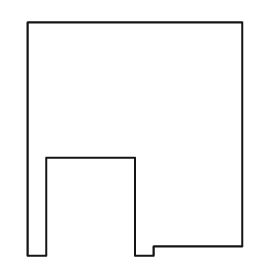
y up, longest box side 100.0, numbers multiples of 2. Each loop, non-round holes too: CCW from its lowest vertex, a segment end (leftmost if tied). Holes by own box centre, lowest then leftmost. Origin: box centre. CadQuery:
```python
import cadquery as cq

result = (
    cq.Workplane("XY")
    .moveTo(-46.0, -50.0)
    .lineTo(-38.0, -50.0)
    .lineTo(-38.0, -8.0)
    .lineTo(0.0, -8.0)
    .lineTo(0.0, -50.0)
    .lineTo(8.0, -50.0)
    .lineTo(8.0, -46.0)
    .lineTo(46.0, -46.0)
    .lineTo(46.0, 50.0)
    .lineTo(-46.0, 50.0)
    .close()
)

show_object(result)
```